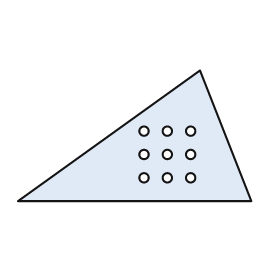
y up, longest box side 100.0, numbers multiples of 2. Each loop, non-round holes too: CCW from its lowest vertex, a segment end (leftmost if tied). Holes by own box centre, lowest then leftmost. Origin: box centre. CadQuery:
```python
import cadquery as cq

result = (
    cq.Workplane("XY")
    .moveTo(-50.0, -28.0)
    .lineTo(50.0, -28.0)
    .lineTo(28.0, 28.0)
    .close()
    .moveTo(4.0, -18.0)
    .circle(2.0)
    .moveTo(14.0, -18.0)
    .circle(2.0)
    .moveTo(24.0, -18.0)
    .circle(2.0)
    .moveTo(4.0, -8.0)
    .circle(2.0)
    .moveTo(14.0, -8.0)
    .circle(2.0)
    .moveTo(24.0, -8.0)
    .circle(2.0)
    .moveTo(4.0, 2.0)
    .circle(2.0)
    .moveTo(14.0, 2.0)
    .circle(2.0)
    .moveTo(24.0, 2.0)
    .circle(2.0)
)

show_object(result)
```